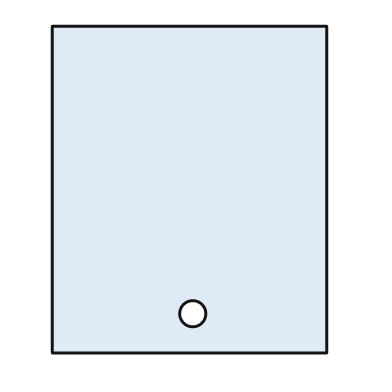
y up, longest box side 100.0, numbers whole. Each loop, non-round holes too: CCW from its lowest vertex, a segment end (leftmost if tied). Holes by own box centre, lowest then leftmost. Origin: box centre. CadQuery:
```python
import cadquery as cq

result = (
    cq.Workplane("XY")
    .moveTo(-42.0, -50.0)
    .lineTo(42.0, -50.0)
    .lineTo(42.0, 50.0)
    .lineTo(-42.0, 50.0)
    .close()
    .moveTo(1.0, -38.0)
    .circle(4.0)
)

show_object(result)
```